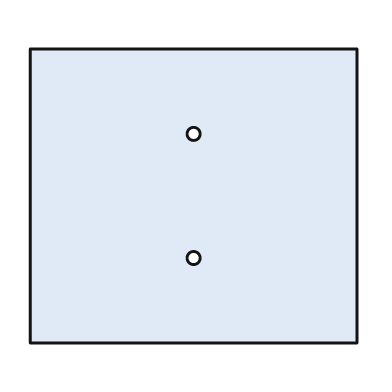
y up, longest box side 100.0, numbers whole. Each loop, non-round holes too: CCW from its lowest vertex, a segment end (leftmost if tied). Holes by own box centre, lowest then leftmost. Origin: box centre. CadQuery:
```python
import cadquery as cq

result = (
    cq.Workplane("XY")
    .moveTo(-50.0, -45.0)
    .lineTo(50.0, -45.0)
    .lineTo(50.0, 45.0)
    .lineTo(-50.0, 45.0)
    .close()
    .moveTo(0.0, -19.0)
    .circle(2.0)
    .moveTo(0.0, 19.0)
    .circle(2.0)
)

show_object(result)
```